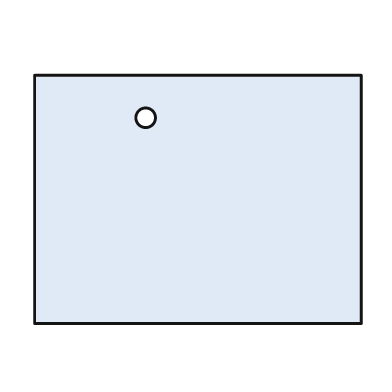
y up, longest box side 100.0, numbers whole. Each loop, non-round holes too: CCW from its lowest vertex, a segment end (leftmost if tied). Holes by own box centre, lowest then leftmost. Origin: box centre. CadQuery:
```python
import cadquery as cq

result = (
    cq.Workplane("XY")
    .moveTo(-50.0, -38.0)
    .lineTo(50.0, -38.0)
    .lineTo(50.0, 38.0)
    .lineTo(-50.0, 38.0)
    .close()
    .moveTo(-16.0, 25.0)
    .circle(3.0)
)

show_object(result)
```